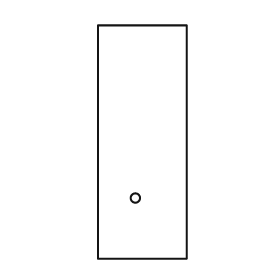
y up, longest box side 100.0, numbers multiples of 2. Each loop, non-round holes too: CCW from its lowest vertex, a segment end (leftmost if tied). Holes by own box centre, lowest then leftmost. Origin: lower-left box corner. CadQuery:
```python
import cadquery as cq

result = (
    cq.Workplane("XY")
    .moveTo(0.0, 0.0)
    .lineTo(38.0, 0.0)
    .lineTo(38.0, 100.0)
    .lineTo(0.0, 100.0)
    .close()
    .moveTo(16.0, 26.0)
    .circle(2.0)
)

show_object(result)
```